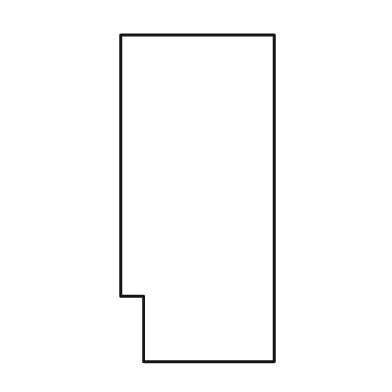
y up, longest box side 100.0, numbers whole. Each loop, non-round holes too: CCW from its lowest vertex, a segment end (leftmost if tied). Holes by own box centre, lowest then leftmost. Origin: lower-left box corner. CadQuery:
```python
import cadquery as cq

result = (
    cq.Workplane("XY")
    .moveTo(7.0, 0.0)
    .lineTo(47.0, 0.0)
    .lineTo(47.0, 100.0)
    .lineTo(0.0, 100.0)
    .lineTo(0.0, 20.0)
    .lineTo(7.0, 20.0)
    .close()
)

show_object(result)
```